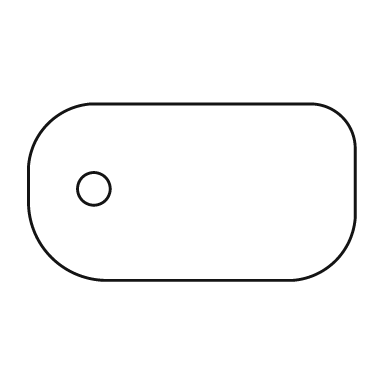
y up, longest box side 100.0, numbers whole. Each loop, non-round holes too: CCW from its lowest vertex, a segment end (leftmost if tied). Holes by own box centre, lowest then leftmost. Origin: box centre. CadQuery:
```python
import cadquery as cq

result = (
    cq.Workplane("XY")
    .moveTo(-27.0, -27.0)
    .lineTo(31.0, -27.0)
    .threePointArc((44.0, -21.0), (50.0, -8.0))
    .lineTo(50.0, 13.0)
    .threePointArc((46.0, 23.0), (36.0, 27.0))
    .lineTo(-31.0, 27.0)
    .threePointArc((-44.0, 21.0), (-50.0, 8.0))
    .lineTo(-50.0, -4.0)
    .threePointArc((-43.0, -20.0), (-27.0, -27.0))
    .close()
    .moveTo(-30.0, 1.0)
    .circle(5.0)
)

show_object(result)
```